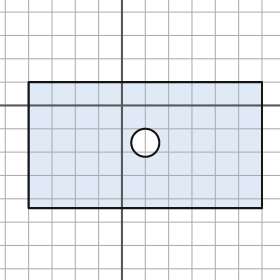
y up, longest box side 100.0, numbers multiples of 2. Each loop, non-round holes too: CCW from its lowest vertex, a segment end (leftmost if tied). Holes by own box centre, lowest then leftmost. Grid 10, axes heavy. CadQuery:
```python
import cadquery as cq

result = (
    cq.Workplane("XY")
    .moveTo(-40.0, -44.0)
    .lineTo(60.0, -44.0)
    .lineTo(60.0, 10.0)
    .lineTo(-40.0, 10.0)
    .close()
    .moveTo(10.0, -16.0)
    .circle(6.0)
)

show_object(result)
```